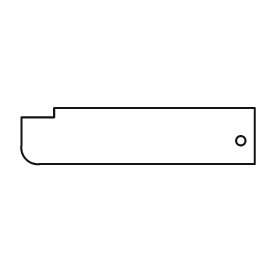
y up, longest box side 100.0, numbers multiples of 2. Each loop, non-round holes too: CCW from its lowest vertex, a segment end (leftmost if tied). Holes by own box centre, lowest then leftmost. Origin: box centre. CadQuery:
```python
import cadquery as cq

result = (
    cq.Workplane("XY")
    .moveTo(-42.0, -12.0)
    .lineTo(50.0, -12.0)
    .lineTo(50.0, 12.0)
    .lineTo(-36.0, 12.0)
    .lineTo(-36.0, 8.0)
    .lineTo(-50.0, 8.0)
    .lineTo(-50.0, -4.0)
    .threePointArc((-48.0, -10.0), (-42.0, -12.0))
    .close()
    .moveTo(44.0, -2.0)
    .circle(2.0)
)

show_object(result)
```